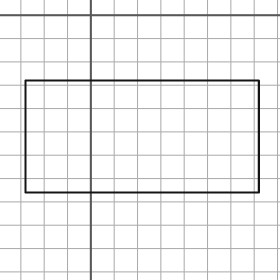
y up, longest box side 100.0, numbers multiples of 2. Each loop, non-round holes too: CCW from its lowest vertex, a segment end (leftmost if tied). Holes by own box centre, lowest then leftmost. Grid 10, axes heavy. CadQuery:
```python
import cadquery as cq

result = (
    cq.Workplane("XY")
    .moveTo(-28.0, -76.0)
    .lineTo(72.0, -76.0)
    .lineTo(72.0, -28.0)
    .lineTo(-28.0, -28.0)
    .close()
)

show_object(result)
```